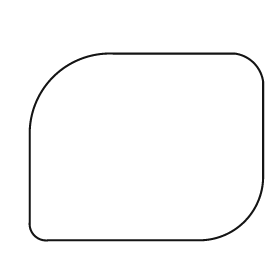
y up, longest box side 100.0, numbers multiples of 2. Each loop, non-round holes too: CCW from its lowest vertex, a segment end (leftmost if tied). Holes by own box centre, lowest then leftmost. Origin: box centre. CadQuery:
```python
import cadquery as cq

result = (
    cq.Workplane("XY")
    .moveTo(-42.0, -40.0)
    .lineTo(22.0, -40.0)
    .threePointArc((42.0, -32.0), (50.0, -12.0))
    .lineTo(50.0, 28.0)
    .threePointArc((46.0, 36.0), (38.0, 40.0))
    .lineTo(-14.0, 40.0)
    .threePointArc((-40.0, 30.0), (-50.0, 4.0))
    .lineTo(-50.0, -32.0)
    .threePointArc((-48.0, -38.0), (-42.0, -40.0))
    .close()
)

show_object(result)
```